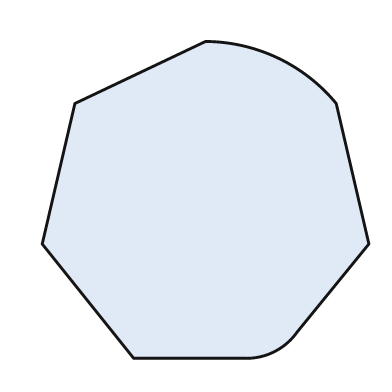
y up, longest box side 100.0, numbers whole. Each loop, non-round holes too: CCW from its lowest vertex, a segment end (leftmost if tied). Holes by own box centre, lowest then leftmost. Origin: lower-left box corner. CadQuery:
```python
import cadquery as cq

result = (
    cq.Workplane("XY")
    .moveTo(28.0, 0.0)
    .lineTo(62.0, 0.0)
    .threePointArc((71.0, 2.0), (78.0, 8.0))
    .lineTo(100.0, 35.0)
    .lineTo(90.0, 78.0)
    .threePointArc((72.0, 92.0), (50.0, 97.0))
    .lineTo(10.0, 78.0)
    .lineTo(0.0, 35.0)
    .close()
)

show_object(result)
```